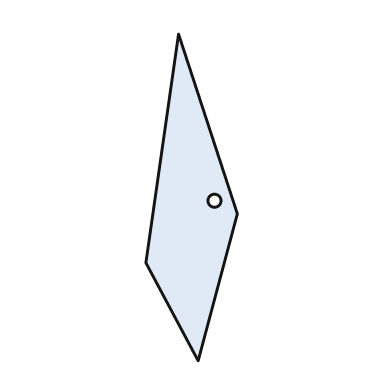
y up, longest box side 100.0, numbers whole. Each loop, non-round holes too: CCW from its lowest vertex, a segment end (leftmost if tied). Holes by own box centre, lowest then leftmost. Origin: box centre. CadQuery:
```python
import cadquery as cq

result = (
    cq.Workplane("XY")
    .moveTo(2.0, -50.0)
    .lineTo(14.0, -5.0)
    .lineTo(-4.0, 50.0)
    .lineTo(-14.0, -20.0)
    .close()
    .moveTo(7.0, -1.0)
    .circle(2.0)
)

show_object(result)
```